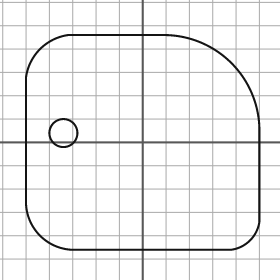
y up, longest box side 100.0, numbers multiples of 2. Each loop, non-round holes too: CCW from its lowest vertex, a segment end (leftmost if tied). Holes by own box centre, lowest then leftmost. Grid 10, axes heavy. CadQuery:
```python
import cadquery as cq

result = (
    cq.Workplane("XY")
    .moveTo(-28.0, -46.0)
    .lineTo(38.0, -46.0)
    .threePointArc((46.0, -42.0), (50.0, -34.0))
    .lineTo(50.0, 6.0)
    .threePointArc((38.0, 34.0), (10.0, 46.0))
    .lineTo(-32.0, 46.0)
    .threePointArc((-44.0, 40.0), (-50.0, 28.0))
    .lineTo(-50.0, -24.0)
    .threePointArc((-44.0, -40.0), (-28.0, -46.0))
    .close()
    .moveTo(-34.0, 4.0)
    .circle(6.0)
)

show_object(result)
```